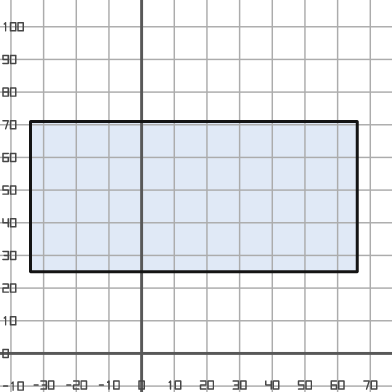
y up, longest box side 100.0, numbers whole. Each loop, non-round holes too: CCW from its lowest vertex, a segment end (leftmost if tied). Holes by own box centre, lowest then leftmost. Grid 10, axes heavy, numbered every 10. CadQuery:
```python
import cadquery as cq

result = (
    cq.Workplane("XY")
    .moveTo(-34.0, 25.0)
    .lineTo(66.0, 25.0)
    .lineTo(66.0, 71.0)
    .lineTo(-34.0, 71.0)
    .close()
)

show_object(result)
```